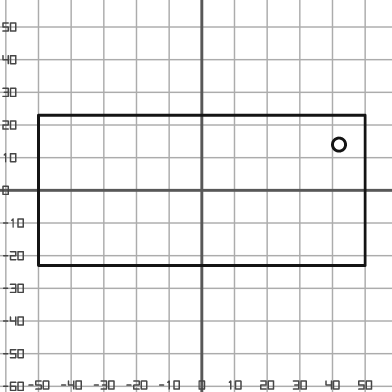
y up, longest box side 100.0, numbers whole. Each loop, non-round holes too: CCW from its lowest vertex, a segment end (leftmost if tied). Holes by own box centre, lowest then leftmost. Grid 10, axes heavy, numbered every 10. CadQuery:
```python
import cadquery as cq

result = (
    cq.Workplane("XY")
    .moveTo(-50.0, -23.0)
    .lineTo(50.0, -23.0)
    .lineTo(50.0, 23.0)
    .lineTo(-50.0, 23.0)
    .close()
    .moveTo(42.0, 14.0)
    .circle(2.0)
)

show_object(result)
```